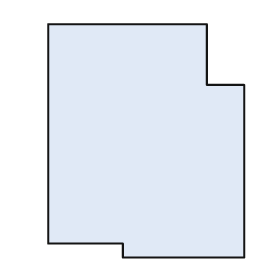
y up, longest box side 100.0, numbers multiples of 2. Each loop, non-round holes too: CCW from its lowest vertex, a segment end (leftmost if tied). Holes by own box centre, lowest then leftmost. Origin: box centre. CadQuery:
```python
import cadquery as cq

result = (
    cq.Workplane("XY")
    .moveTo(-10.0, -50.0)
    .lineTo(42.0, -50.0)
    .lineTo(42.0, 24.0)
    .lineTo(26.0, 24.0)
    .lineTo(26.0, 50.0)
    .lineTo(-42.0, 50.0)
    .lineTo(-42.0, -44.0)
    .lineTo(-10.0, -44.0)
    .close()
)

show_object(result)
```